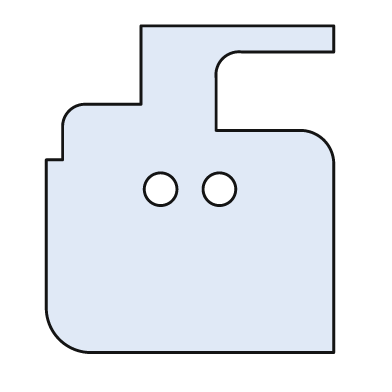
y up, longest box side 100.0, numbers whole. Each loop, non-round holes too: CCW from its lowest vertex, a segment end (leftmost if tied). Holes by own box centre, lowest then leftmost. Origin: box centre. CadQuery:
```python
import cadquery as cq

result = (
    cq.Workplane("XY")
    .moveTo(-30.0, -50.0)
    .lineTo(44.0, -50.0)
    .lineTo(44.0, 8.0)
    .threePointArc((41.0, 15.0), (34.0, 18.0))
    .lineTo(8.0, 18.0)
    .lineTo(8.0, 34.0)
    .threePointArc((10.0, 40.0), (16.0, 42.0))
    .lineTo(44.0, 42.0)
    .lineTo(44.0, 50.0)
    .lineTo(-15.0, 50.0)
    .lineTo(-15.0, 26.0)
    .lineTo(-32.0, 26.0)
    .threePointArc((-37.0, 24.0), (-39.0, 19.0))
    .lineTo(-39.0, 9.0)
    .lineTo(-44.0, 9.0)
    .lineTo(-44.0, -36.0)
    .threePointArc((-40.0, -46.0), (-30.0, -50.0))
    .close()
    .moveTo(-9.0, 0.0)
    .circle(5.0)
    .moveTo(9.0, 0.0)
    .circle(5.0)
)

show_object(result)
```